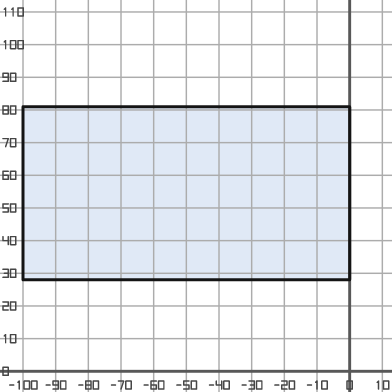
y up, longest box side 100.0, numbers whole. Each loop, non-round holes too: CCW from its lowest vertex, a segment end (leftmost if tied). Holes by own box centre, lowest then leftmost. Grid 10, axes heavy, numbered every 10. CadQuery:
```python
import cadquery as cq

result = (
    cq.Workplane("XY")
    .moveTo(-100.0, 28.0)
    .lineTo(0.0, 28.0)
    .lineTo(0.0, 81.0)
    .lineTo(-100.0, 81.0)
    .close()
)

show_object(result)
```